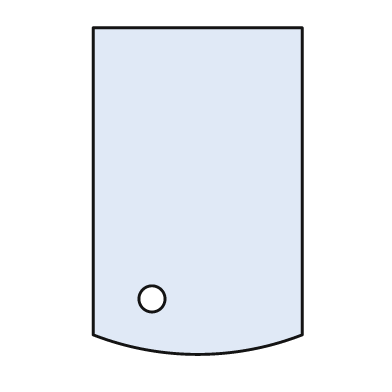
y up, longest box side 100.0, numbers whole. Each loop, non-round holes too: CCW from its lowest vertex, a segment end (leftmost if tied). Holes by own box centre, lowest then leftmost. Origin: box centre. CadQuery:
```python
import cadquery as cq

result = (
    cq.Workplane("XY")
    .moveTo(-32.0, -44.0)
    .threePointArc((0.0, -50.0), (32.0, -44.0))
    .lineTo(32.0, 50.0)
    .lineTo(-32.0, 50.0)
    .close()
    .moveTo(-14.0, -33.0)
    .circle(4.0)
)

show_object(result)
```